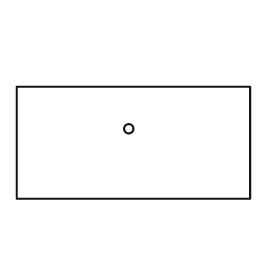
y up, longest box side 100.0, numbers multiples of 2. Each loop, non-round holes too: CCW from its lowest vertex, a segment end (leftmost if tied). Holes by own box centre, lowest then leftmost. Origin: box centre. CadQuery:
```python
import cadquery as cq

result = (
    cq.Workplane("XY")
    .moveTo(-50.0, -24.0)
    .lineTo(50.0, -24.0)
    .lineTo(50.0, 24.0)
    .lineTo(-50.0, 24.0)
    .close()
    .moveTo(-2.0, 6.0)
    .circle(2.0)
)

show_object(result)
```